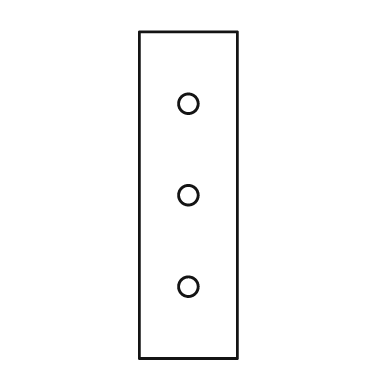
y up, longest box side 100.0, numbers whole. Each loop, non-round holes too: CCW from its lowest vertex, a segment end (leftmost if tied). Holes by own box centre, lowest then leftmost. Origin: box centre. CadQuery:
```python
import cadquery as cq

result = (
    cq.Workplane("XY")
    .moveTo(-15.0, -50.0)
    .lineTo(15.0, -50.0)
    .lineTo(15.0, 50.0)
    .lineTo(-15.0, 50.0)
    .close()
    .moveTo(0.0, -28.0)
    .circle(3.0)
    .moveTo(0.0, 0.0)
    .circle(3.0)
    .moveTo(0.0, 28.0)
    .circle(3.0)
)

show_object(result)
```